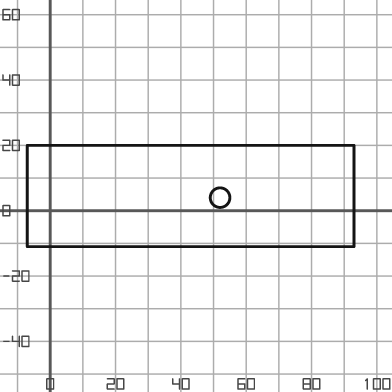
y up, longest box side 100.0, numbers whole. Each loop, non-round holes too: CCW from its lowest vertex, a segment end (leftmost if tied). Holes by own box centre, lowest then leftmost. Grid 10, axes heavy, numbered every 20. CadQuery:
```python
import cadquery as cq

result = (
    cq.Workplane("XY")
    .moveTo(-7.0, -11.0)
    .lineTo(93.0, -11.0)
    .lineTo(93.0, 20.0)
    .lineTo(-7.0, 20.0)
    .close()
    .moveTo(52.0, 4.0)
    .circle(3.0)
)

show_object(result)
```